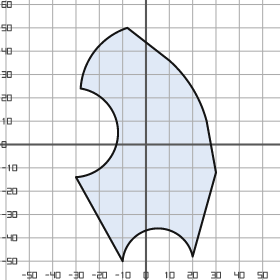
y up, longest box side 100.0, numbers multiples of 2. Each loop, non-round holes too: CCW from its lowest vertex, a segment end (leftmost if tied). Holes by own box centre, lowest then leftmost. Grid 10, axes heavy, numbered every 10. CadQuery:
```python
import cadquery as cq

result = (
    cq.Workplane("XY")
    .moveTo(-10.0, -50.0)
    .threePointArc((4.0, -36.0), (20.0, -48.0))
    .lineTo(30.0, -12.0)
    .lineTo(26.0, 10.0)
    .threePointArc((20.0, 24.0), (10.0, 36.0))
    .lineTo(-8.0, 50.0)
    .threePointArc((-22.0, 40.0), (-28.0, 24.0))
    .threePointArc((-12.0, 4.0), (-30.0, -14.0))
    .close()
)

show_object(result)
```